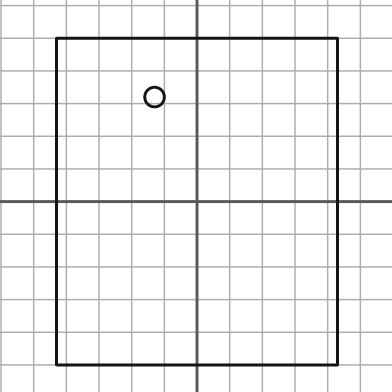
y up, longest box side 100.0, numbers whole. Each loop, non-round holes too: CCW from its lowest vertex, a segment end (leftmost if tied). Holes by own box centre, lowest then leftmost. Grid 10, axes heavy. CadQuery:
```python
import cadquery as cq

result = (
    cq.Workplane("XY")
    .moveTo(-43.0, -50.0)
    .lineTo(43.0, -50.0)
    .lineTo(43.0, 50.0)
    .lineTo(-43.0, 50.0)
    .close()
    .moveTo(-13.0, 32.0)
    .circle(3.0)
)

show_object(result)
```